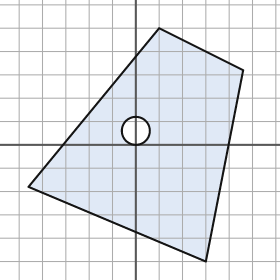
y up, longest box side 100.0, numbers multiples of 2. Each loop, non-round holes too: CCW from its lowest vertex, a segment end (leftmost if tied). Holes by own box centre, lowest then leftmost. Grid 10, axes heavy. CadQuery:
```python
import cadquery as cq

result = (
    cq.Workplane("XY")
    .moveTo(30.0, -50.0)
    .lineTo(46.0, 32.0)
    .lineTo(10.0, 50.0)
    .lineTo(-46.0, -18.0)
    .close()
    .moveTo(0.0, 6.0)
    .circle(6.0)
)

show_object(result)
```